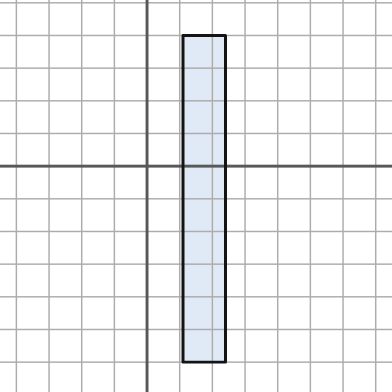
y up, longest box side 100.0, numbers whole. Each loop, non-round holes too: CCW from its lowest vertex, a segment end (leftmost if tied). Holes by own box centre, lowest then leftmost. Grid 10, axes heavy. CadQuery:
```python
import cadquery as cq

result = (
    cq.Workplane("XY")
    .moveTo(11.0, -60.0)
    .lineTo(24.0, -60.0)
    .lineTo(24.0, 40.0)
    .lineTo(11.0, 40.0)
    .close()
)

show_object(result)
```